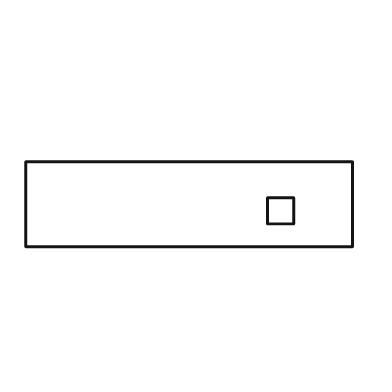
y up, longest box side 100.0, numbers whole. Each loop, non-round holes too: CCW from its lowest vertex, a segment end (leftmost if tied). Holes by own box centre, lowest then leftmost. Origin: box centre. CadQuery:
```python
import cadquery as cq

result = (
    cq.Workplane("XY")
    .moveTo(-50.0, -13.0)
    .lineTo(50.0, -13.0)
    .lineTo(50.0, 13.0)
    .lineTo(-50.0, 13.0)
    .close()
    .moveTo(24.0, -6.0)
    .lineTo(32.0, -6.0)
    .lineTo(32.0, 2.0)
    .lineTo(24.0, 2.0)
    .close()
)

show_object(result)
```